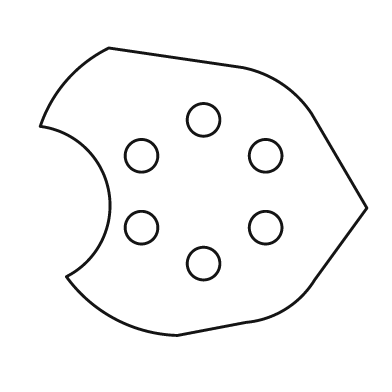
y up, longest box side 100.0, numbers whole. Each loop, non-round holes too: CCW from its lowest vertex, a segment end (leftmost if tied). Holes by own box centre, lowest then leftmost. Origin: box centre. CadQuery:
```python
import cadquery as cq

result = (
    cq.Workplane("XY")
    .moveTo(-8.0, -44.0)
    .lineTo(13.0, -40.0)
    .threePointArc((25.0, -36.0), (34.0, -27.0))
    .lineTo(50.0, -5.0)
    .lineTo(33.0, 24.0)
    .threePointArc((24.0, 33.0), (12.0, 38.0))
    .lineTo(-29.0, 44.0)
    .threePointArc((-42.0, 34.0), (-50.0, 20.0))
    .threePointArc((-29.0, 0.0), (-42.0, -26.0))
    .threePointArc((-27.0, -39.0), (-8.0, -44.0))
    .close()
    .moveTo(0.0, -22.0)
    .circle(5.0)
    .moveTo(-19.0, -11.0)
    .circle(5.0)
    .moveTo(19.0, -11.0)
    .circle(5.0)
    .moveTo(-19.0, 11.0)
    .circle(5.0)
    .moveTo(19.0, 11.0)
    .circle(5.0)
    .moveTo(0.0, 22.0)
    .circle(5.0)
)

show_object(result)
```